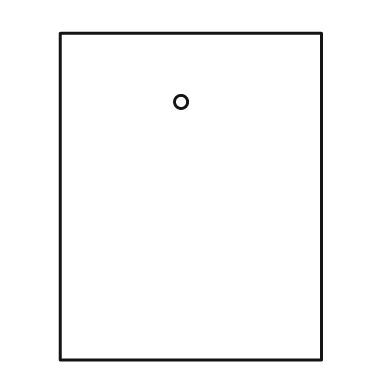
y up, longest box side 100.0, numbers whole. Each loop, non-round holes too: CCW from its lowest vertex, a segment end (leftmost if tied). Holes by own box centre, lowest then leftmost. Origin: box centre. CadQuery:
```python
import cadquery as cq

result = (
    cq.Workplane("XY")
    .moveTo(-40.0, -50.0)
    .lineTo(40.0, -50.0)
    .lineTo(40.0, 50.0)
    .lineTo(-40.0, 50.0)
    .close()
    .moveTo(-3.0, 29.0)
    .circle(2.0)
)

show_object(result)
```